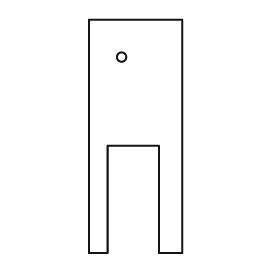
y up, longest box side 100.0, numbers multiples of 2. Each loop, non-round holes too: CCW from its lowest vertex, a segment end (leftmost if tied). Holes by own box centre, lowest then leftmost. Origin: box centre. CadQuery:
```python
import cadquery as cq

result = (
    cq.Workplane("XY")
    .moveTo(-20.0, -50.0)
    .lineTo(-12.0, -50.0)
    .lineTo(-12.0, -4.0)
    .lineTo(10.0, -4.0)
    .lineTo(10.0, -50.0)
    .lineTo(20.0, -50.0)
    .lineTo(20.0, 50.0)
    .lineTo(-20.0, 50.0)
    .close()
    .moveTo(-6.0, 34.0)
    .circle(2.0)
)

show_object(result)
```